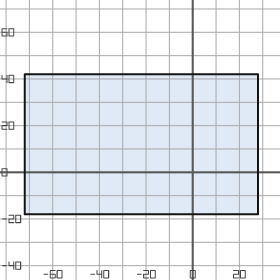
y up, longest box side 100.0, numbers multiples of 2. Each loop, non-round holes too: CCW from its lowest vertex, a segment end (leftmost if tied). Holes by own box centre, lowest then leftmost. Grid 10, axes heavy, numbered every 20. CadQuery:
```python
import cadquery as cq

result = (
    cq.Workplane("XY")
    .moveTo(-72.0, -18.0)
    .lineTo(28.0, -18.0)
    .lineTo(28.0, 42.0)
    .lineTo(-72.0, 42.0)
    .close()
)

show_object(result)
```